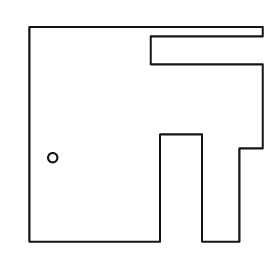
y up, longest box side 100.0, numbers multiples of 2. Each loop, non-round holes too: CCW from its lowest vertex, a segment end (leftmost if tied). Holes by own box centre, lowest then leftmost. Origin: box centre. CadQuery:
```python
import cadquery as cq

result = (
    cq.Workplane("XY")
    .moveTo(-50.0, -46.0)
    .lineTo(6.0, -46.0)
    .lineTo(6.0, 0.0)
    .lineTo(24.0, 0.0)
    .lineTo(24.0, -46.0)
    .lineTo(40.0, -46.0)
    .lineTo(40.0, -6.0)
    .lineTo(50.0, -6.0)
    .lineTo(50.0, 30.0)
    .lineTo(2.0, 30.0)
    .lineTo(2.0, 42.0)
    .lineTo(50.0, 42.0)
    .lineTo(50.0, 46.0)
    .lineTo(-50.0, 46.0)
    .close()
    .moveTo(-40.0, -10.0)
    .circle(2.0)
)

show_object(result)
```